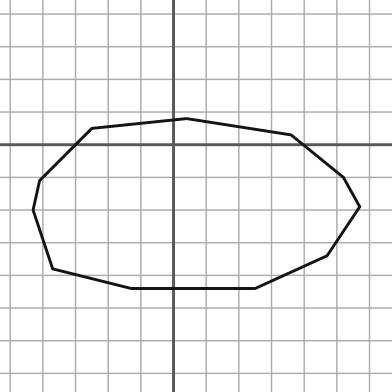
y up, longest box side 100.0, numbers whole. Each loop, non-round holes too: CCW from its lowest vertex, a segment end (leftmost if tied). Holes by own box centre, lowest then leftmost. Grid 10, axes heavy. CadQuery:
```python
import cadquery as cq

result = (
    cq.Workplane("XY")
    .moveTo(-13.0, -44.0)
    .lineTo(25.0, -44.0)
    .lineTo(47.0, -34.0)
    .lineTo(57.0, -19.0)
    .lineTo(52.0, -10.0)
    .lineTo(36.0, 3.0)
    .lineTo(4.0, 8.0)
    .lineTo(-25.0, 5.0)
    .lineTo(-41.0, -11.0)
    .lineTo(-43.0, -20.0)
    .lineTo(-37.0, -38.0)
    .close()
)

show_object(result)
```